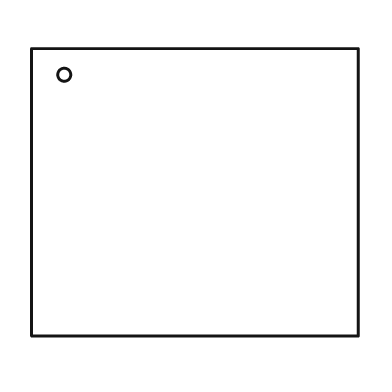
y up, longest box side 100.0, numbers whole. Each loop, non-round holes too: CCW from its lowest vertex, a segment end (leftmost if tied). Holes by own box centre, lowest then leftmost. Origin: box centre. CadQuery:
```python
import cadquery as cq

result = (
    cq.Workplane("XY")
    .moveTo(-50.0, -44.0)
    .lineTo(50.0, -44.0)
    .lineTo(50.0, 44.0)
    .lineTo(-50.0, 44.0)
    .close()
    .moveTo(-40.0, 36.0)
    .circle(2.0)
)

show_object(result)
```